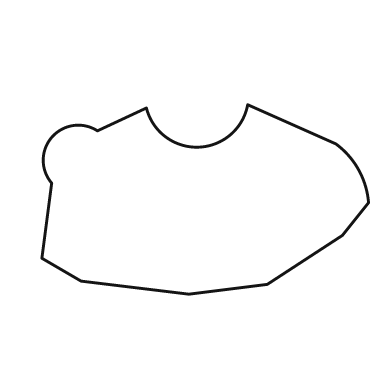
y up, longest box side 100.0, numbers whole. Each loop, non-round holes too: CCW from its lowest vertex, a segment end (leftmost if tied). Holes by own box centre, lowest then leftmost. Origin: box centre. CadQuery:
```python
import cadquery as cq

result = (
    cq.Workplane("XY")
    .moveTo(-5.0, -29.0)
    .lineTo(19.0, -26.0)
    .lineTo(42.0, -11.0)
    .lineTo(50.0, -1.0)
    .threePointArc((47.0, 9.0), (40.0, 17.0))
    .lineTo(13.0, 29.0)
    .threePointArc((-2.0, 16.0), (-18.0, 28.0))
    .lineTo(-33.0, 21.0)
    .threePointArc((-47.0, 19.0), (-47.0, 5.0))
    .lineTo(-50.0, -18.0)
    .lineTo(-38.0, -25.0)
    .close()
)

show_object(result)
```